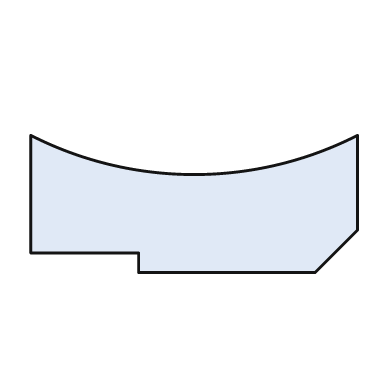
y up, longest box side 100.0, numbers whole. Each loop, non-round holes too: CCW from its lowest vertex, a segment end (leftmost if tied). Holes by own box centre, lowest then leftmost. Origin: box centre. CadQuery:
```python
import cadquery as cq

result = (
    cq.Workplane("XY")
    .moveTo(-17.0, -21.0)
    .lineTo(37.0, -21.0)
    .lineTo(50.0, -8.0)
    .lineTo(50.0, 21.0)
    .threePointArc((0.0, 9.0), (-50.0, 21.0))
    .lineTo(-50.0, -15.0)
    .lineTo(-17.0, -15.0)
    .close()
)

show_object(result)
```